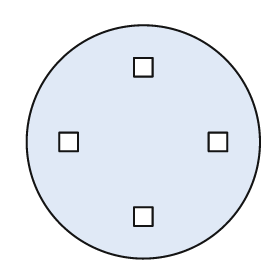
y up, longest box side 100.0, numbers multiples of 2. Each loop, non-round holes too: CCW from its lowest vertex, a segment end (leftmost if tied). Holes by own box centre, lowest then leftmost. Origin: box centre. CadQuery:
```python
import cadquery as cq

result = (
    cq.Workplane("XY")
    .moveTo(0.0, 0.0)
    .circle(50.0)
    .moveTo(-4.0, -36.0)
    .lineTo(4.0, -36.0)
    .lineTo(4.0, -28.0)
    .lineTo(-4.0, -28.0)
    .close()
    .moveTo(-36.0, -4.0)
    .lineTo(-28.0, -4.0)
    .lineTo(-28.0, 4.0)
    .lineTo(-36.0, 4.0)
    .close()
    .moveTo(28.0, -4.0)
    .lineTo(36.0, -4.0)
    .lineTo(36.0, 4.0)
    .lineTo(28.0, 4.0)
    .close()
    .moveTo(-4.0, 28.0)
    .lineTo(4.0, 28.0)
    .lineTo(4.0, 36.0)
    .lineTo(-4.0, 36.0)
    .close()
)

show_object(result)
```